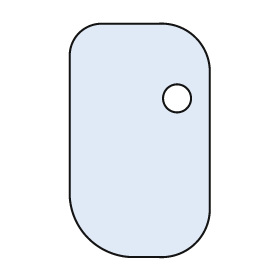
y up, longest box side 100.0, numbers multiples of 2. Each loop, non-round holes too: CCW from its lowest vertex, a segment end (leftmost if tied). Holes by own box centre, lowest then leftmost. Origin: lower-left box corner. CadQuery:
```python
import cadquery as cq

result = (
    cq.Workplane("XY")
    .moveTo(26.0, 0.0)
    .lineTo(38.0, 0.0)
    .threePointArc((54.0, 6.0), (60.0, 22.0))
    .lineTo(60.0, 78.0)
    .threePointArc((54.0, 94.0), (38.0, 100.0))
    .lineTo(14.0, 100.0)
    .threePointArc((4.0, 96.0), (0.0, 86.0))
    .lineTo(0.0, 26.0)
    .threePointArc((8.0, 8.0), (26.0, 0.0))
    .close()
    .moveTo(46.0, 68.0)
    .circle(6.0)
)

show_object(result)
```